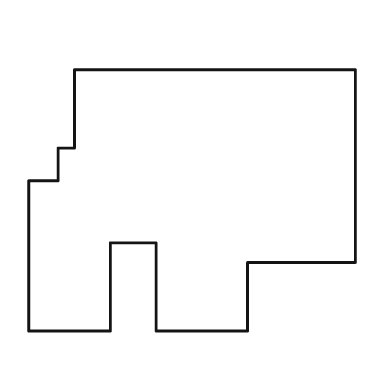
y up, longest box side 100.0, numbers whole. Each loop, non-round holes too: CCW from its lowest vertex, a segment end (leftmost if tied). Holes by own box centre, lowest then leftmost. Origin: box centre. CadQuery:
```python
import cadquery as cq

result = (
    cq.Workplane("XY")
    .moveTo(-50.0, -40.0)
    .lineTo(-25.0, -40.0)
    .lineTo(-25.0, -13.0)
    .lineTo(-11.0, -13.0)
    .lineTo(-11.0, -40.0)
    .lineTo(17.0, -40.0)
    .lineTo(17.0, -19.0)
    .lineTo(50.0, -19.0)
    .lineTo(50.0, 40.0)
    .lineTo(-36.0, 40.0)
    .lineTo(-36.0, 16.0)
    .lineTo(-41.0, 16.0)
    .lineTo(-41.0, 6.0)
    .lineTo(-50.0, 6.0)
    .close()
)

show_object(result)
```